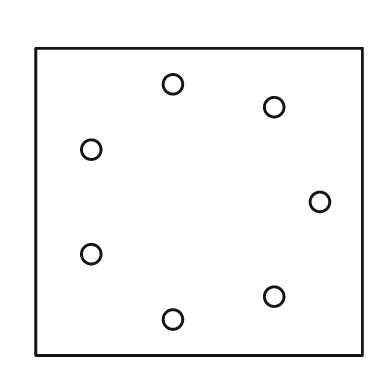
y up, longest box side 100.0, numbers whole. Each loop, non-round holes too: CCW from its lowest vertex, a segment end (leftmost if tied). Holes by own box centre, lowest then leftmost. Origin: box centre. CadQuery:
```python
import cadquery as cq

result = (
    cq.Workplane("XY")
    .moveTo(-50.0, -47.0)
    .lineTo(50.0, -47.0)
    .lineTo(50.0, 47.0)
    .lineTo(-50.0, 47.0)
    .close()
    .moveTo(-8.0, -36.0)
    .circle(3.0)
    .moveTo(23.0, -29.0)
    .circle(3.0)
    .moveTo(-33.0, -16.0)
    .circle(3.0)
    .moveTo(37.0, 0.0)
    .circle(3.0)
    .moveTo(-33.0, 16.0)
    .circle(3.0)
    .moveTo(23.0, 29.0)
    .circle(3.0)
    .moveTo(-8.0, 36.0)
    .circle(3.0)
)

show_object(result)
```